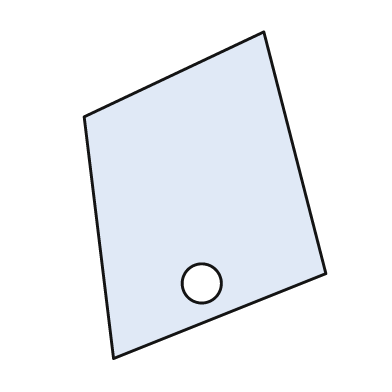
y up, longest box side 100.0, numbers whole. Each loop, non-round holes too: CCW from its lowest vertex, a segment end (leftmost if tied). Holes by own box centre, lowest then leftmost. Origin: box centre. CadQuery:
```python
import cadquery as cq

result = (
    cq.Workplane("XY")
    .moveTo(-28.0, -50.0)
    .lineTo(37.0, -24.0)
    .lineTo(18.0, 50.0)
    .lineTo(-37.0, 24.0)
    .close()
    .moveTo(-1.0, -27.0)
    .circle(6.0)
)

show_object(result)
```